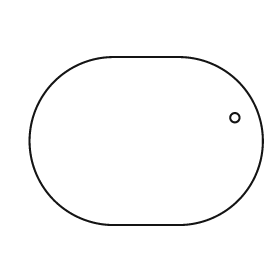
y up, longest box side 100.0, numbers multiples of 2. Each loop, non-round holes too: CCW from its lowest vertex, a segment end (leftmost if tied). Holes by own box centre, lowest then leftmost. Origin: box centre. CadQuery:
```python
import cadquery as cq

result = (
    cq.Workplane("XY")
    .moveTo(-14.0, -36.0)
    .lineTo(14.0, -36.0)
    .threePointArc((50.0, 0.0), (14.0, 36.0))
    .lineTo(-14.0, 36.0)
    .threePointArc((-50.0, 0.0), (-14.0, -36.0))
    .close()
    .moveTo(38.0, 10.0)
    .circle(2.0)
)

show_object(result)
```